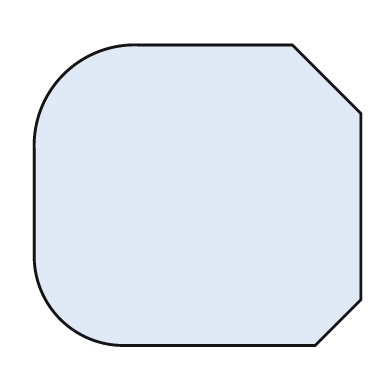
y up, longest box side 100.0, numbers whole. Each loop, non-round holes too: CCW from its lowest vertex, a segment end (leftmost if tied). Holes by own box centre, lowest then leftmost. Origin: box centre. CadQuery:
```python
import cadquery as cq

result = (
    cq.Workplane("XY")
    .moveTo(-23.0, -46.0)
    .lineTo(36.0, -46.0)
    .lineTo(50.0, -32.0)
    .lineTo(50.0, 25.0)
    .lineTo(29.0, 46.0)
    .lineTo(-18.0, 46.0)
    .threePointArc((-41.0, 37.0), (-50.0, 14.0))
    .lineTo(-50.0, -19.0)
    .threePointArc((-42.0, -38.0), (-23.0, -46.0))
    .close()
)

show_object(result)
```